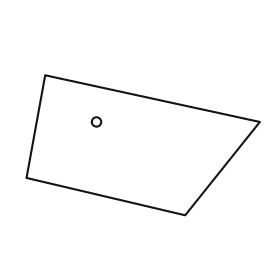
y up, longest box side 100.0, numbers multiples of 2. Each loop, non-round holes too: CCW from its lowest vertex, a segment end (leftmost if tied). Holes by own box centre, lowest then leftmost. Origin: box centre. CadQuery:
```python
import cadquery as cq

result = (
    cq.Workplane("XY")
    .moveTo(18.0, -30.0)
    .lineTo(50.0, 10.0)
    .lineTo(-42.0, 30.0)
    .lineTo(-50.0, -14.0)
    .close()
    .moveTo(-20.0, 10.0)
    .circle(2.0)
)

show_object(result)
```